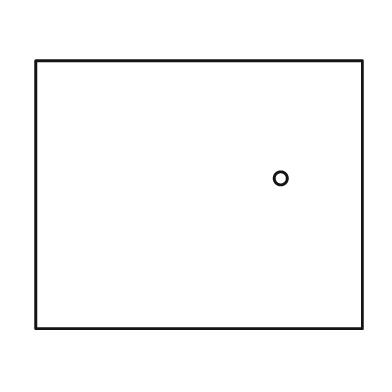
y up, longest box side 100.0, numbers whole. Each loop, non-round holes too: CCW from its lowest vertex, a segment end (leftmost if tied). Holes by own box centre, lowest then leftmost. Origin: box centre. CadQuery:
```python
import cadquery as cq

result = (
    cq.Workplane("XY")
    .moveTo(-50.0, -41.0)
    .lineTo(50.0, -41.0)
    .lineTo(50.0, 41.0)
    .lineTo(-50.0, 41.0)
    .close()
    .moveTo(25.0, 5.0)
    .circle(2.0)
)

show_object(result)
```